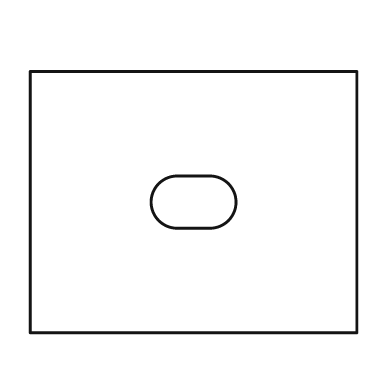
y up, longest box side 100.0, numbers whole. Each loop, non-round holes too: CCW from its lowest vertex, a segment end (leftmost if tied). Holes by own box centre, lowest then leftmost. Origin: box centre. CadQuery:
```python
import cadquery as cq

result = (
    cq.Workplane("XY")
    .moveTo(-50.0, -40.0)
    .lineTo(50.0, -40.0)
    .lineTo(50.0, 40.0)
    .lineTo(-50.0, 40.0)
    .close()
    .moveTo(-5.0, -8.0)
    .lineTo(5.0, -8.0)
    .threePointArc((13.0, 0.0), (5.0, 8.0))
    .lineTo(-5.0, 8.0)
    .threePointArc((-13.0, 0.0), (-5.0, -8.0))
    .close()
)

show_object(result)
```